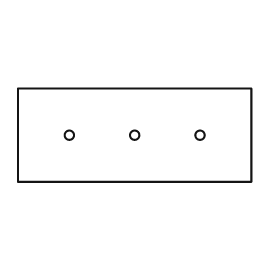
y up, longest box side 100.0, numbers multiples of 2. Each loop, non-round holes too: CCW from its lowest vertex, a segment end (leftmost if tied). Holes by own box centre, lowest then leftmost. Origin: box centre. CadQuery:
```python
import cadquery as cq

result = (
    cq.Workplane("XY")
    .moveTo(-50.0, -20.0)
    .lineTo(50.0, -20.0)
    .lineTo(50.0, 20.0)
    .lineTo(-50.0, 20.0)
    .close()
    .moveTo(-28.0, 0.0)
    .circle(2.0)
    .moveTo(0.0, 0.0)
    .circle(2.0)
    .moveTo(28.0, 0.0)
    .circle(2.0)
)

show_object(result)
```